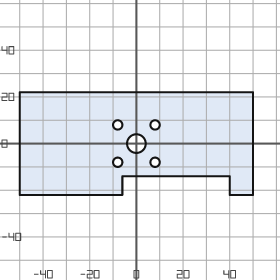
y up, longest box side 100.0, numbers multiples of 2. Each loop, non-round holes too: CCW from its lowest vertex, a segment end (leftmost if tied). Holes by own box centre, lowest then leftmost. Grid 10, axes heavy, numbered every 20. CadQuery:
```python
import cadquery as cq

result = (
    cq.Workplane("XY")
    .moveTo(-50.0, -22.0)
    .lineTo(-6.0, -22.0)
    .lineTo(-6.0, -14.0)
    .lineTo(40.0, -14.0)
    .lineTo(40.0, -22.0)
    .lineTo(50.0, -22.0)
    .lineTo(50.0, 22.0)
    .lineTo(-50.0, 22.0)
    .close()
    .moveTo(-8.0, -8.0)
    .circle(2.0)
    .moveTo(8.0, -8.0)
    .circle(2.0)
    .moveTo(0.0, 0.0)
    .circle(4.0)
    .moveTo(-8.0, 8.0)
    .circle(2.0)
    .moveTo(8.0, 8.0)
    .circle(2.0)
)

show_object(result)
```